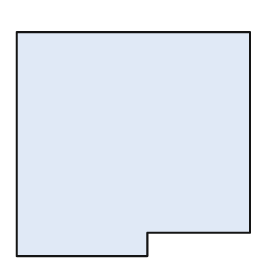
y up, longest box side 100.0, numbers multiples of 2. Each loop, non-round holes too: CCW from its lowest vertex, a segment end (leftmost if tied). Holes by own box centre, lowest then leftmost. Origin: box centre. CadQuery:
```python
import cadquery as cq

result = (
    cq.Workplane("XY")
    .moveTo(-50.0, -48.0)
    .lineTo(6.0, -48.0)
    .lineTo(6.0, -38.0)
    .lineTo(50.0, -38.0)
    .lineTo(50.0, 48.0)
    .lineTo(-50.0, 48.0)
    .close()
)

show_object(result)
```